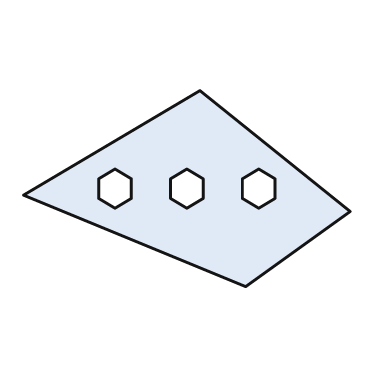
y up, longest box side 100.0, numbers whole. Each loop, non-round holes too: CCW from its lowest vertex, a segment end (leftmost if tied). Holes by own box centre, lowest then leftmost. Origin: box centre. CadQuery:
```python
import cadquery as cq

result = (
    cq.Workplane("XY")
    .moveTo(18.0, -30.0)
    .lineTo(50.0, -7.0)
    .lineTo(4.0, 30.0)
    .lineTo(-50.0, -2.0)
    .close()
    .moveTo(-22.0, -6.0)
    .lineTo(-17.0, -3.0)
    .lineTo(-17.0, 3.0)
    .lineTo(-22.0, 6.0)
    .lineTo(-27.0, 3.0)
    .lineTo(-27.0, -3.0)
    .close()
    .moveTo(0.0, -6.0)
    .lineTo(5.0, -3.0)
    .lineTo(5.0, 3.0)
    .lineTo(0.0, 6.0)
    .lineTo(-5.0, 3.0)
    .lineTo(-5.0, -3.0)
    .close()
    .moveTo(22.0, -6.0)
    .lineTo(27.0, -3.0)
    .lineTo(27.0, 3.0)
    .lineTo(22.0, 6.0)
    .lineTo(17.0, 3.0)
    .lineTo(17.0, -3.0)
    .close()
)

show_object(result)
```